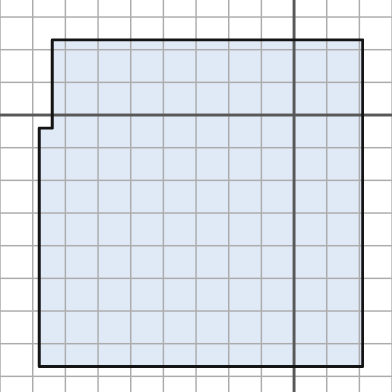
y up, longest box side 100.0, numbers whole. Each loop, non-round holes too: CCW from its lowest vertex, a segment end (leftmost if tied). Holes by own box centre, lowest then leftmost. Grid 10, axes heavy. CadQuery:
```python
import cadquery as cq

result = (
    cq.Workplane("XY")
    .moveTo(-78.0, -77.0)
    .lineTo(21.0, -77.0)
    .lineTo(21.0, 23.0)
    .lineTo(-74.0, 23.0)
    .lineTo(-74.0, -4.0)
    .lineTo(-78.0, -4.0)
    .close()
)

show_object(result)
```